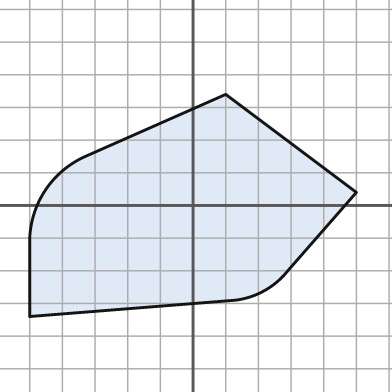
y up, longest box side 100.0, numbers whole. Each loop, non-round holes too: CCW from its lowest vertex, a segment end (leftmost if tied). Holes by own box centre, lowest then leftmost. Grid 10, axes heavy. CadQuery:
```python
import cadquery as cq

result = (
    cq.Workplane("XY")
    .moveTo(-50.0, -34.0)
    .lineTo(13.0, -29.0)
    .threePointArc((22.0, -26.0), (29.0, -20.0))
    .lineTo(50.0, 4.0)
    .lineTo(10.0, 34.0)
    .lineTo(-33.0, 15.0)
    .threePointArc((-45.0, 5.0), (-50.0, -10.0))
    .close()
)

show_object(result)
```